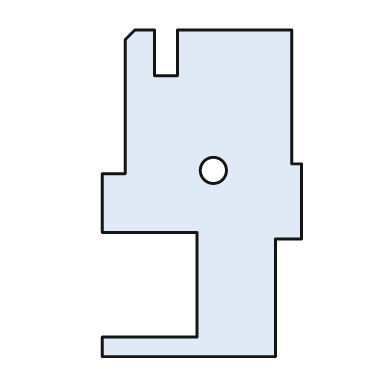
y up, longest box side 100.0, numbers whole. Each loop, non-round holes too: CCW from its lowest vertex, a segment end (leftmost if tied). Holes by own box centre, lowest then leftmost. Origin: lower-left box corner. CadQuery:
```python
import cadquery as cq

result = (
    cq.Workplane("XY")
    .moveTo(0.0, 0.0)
    .lineTo(53.0, 0.0)
    .lineTo(53.0, 36.0)
    .lineTo(61.0, 36.0)
    .lineTo(61.0, 59.0)
    .lineTo(58.0, 59.0)
    .lineTo(58.0, 100.0)
    .lineTo(23.0, 100.0)
    .lineTo(23.0, 86.0)
    .lineTo(16.0, 86.0)
    .lineTo(16.0, 100.0)
    .lineTo(10.0, 100.0)
    .lineTo(7.0, 97.0)
    .lineTo(7.0, 56.0)
    .lineTo(0.0, 56.0)
    .lineTo(0.0, 38.0)
    .lineTo(29.0, 38.0)
    .lineTo(29.0, 6.0)
    .lineTo(0.0, 6.0)
    .close()
    .moveTo(34.0, 57.0)
    .circle(4.0)
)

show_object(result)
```